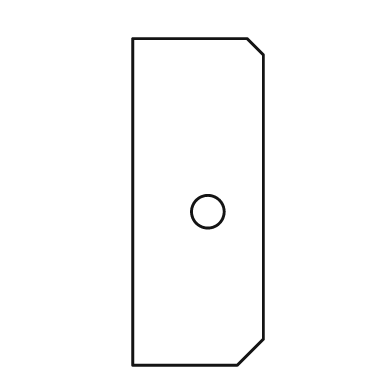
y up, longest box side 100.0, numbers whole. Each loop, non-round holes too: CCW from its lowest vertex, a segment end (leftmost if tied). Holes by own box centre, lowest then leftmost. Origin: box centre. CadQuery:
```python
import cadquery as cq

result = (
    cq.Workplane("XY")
    .moveTo(-20.0, -50.0)
    .lineTo(12.0, -50.0)
    .lineTo(20.0, -42.0)
    .lineTo(20.0, 45.0)
    .lineTo(15.0, 50.0)
    .lineTo(-20.0, 50.0)
    .close()
    .moveTo(3.0, -3.0)
    .circle(5.0)
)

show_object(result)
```